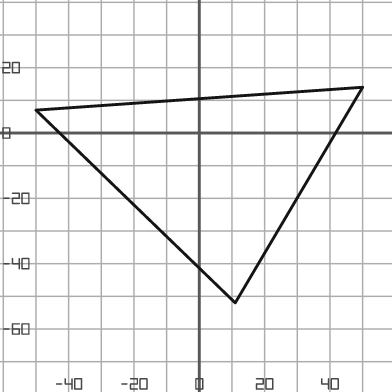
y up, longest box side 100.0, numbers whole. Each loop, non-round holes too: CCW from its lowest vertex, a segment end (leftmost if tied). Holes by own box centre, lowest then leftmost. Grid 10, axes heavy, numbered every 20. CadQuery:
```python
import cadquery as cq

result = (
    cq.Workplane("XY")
    .moveTo(11.0, -52.0)
    .lineTo(50.0, 14.0)
    .lineTo(-50.0, 7.0)
    .close()
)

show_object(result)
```